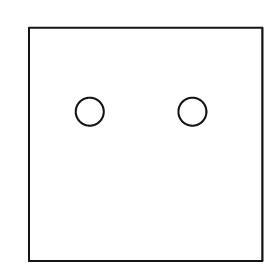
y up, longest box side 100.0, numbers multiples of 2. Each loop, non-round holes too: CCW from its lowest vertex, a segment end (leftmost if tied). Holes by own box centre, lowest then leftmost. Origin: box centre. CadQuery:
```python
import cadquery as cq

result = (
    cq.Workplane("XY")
    .moveTo(-50.0, -50.0)
    .lineTo(50.0, -50.0)
    .lineTo(50.0, 50.0)
    .lineTo(-50.0, 50.0)
    .close()
    .moveTo(-24.0, 14.0)
    .circle(6.0)
    .moveTo(20.0, 14.0)
    .circle(6.0)
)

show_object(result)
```